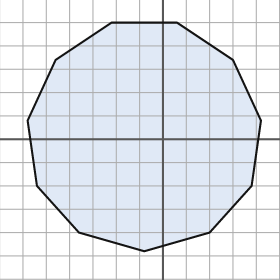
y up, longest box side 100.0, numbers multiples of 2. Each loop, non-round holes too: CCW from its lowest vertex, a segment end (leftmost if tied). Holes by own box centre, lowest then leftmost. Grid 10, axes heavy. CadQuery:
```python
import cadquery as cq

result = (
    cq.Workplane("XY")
    .moveTo(-8.0, -48.0)
    .lineTo(20.0, -40.0)
    .lineTo(38.0, -20.0)
    .lineTo(42.0, 8.0)
    .lineTo(30.0, 34.0)
    .lineTo(6.0, 50.0)
    .lineTo(-22.0, 50.0)
    .lineTo(-46.0, 34.0)
    .lineTo(-58.0, 8.0)
    .lineTo(-54.0, -20.0)
    .lineTo(-36.0, -40.0)
    .close()
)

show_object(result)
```